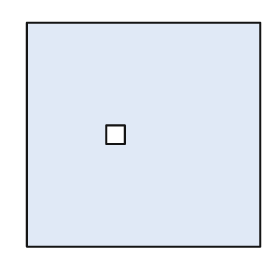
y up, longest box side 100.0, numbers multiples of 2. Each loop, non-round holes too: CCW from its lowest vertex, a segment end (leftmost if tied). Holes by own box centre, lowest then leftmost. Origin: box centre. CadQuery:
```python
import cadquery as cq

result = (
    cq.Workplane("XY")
    .moveTo(-50.0, -48.0)
    .lineTo(50.0, -48.0)
    .lineTo(50.0, 48.0)
    .lineTo(-50.0, 48.0)
    .close()
    .moveTo(-16.0, -4.0)
    .lineTo(-8.0, -4.0)
    .lineTo(-8.0, 4.0)
    .lineTo(-16.0, 4.0)
    .close()
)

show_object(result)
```